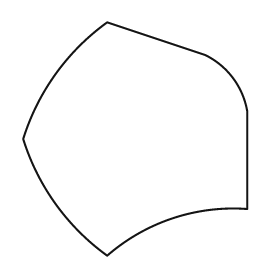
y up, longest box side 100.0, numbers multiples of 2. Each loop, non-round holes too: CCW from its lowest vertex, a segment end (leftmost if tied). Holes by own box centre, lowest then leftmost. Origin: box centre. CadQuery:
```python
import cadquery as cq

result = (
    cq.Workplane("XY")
    .moveTo(-12.0, -50.0)
    .threePointArc((16.0, -34.0), (48.0, -30.0))
    .lineTo(48.0, 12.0)
    .threePointArc((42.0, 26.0), (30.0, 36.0))
    .lineTo(-12.0, 50.0)
    .threePointArc((-34.0, 28.0), (-48.0, 0.0))
    .threePointArc((-34.0, -28.0), (-12.0, -50.0))
    .close()
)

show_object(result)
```